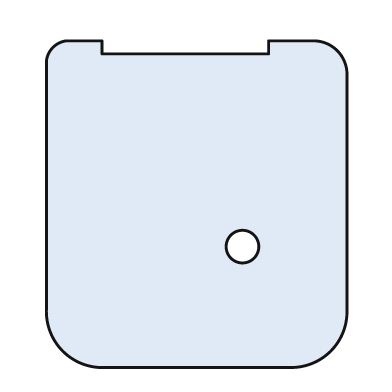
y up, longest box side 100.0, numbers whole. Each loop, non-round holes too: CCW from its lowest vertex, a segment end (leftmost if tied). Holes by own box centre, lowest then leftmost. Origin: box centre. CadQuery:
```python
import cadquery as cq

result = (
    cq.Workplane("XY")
    .moveTo(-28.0, -50.0)
    .lineTo(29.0, -50.0)
    .threePointArc((41.0, -45.0), (46.0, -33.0))
    .lineTo(46.0, 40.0)
    .threePointArc((43.0, 47.0), (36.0, 50.0))
    .lineTo(22.0, 50.0)
    .lineTo(22.0, 46.0)
    .lineTo(-29.0, 46.0)
    .lineTo(-29.0, 50.0)
    .lineTo(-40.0, 50.0)
    .threePointArc((-44.0, 48.0), (-46.0, 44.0))
    .lineTo(-46.0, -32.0)
    .threePointArc((-41.0, -45.0), (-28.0, -50.0))
    .close()
    .moveTo(14.0, -13.0)
    .circle(5.0)
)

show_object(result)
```